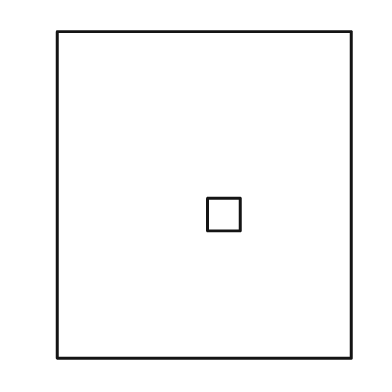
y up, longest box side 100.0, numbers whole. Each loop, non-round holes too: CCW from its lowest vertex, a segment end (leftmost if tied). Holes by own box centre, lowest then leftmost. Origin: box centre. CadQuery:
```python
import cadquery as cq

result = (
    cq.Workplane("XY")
    .moveTo(-45.0, -50.0)
    .lineTo(45.0, -50.0)
    .lineTo(45.0, 50.0)
    .lineTo(-45.0, 50.0)
    .close()
    .moveTo(1.0, -11.0)
    .lineTo(11.0, -11.0)
    .lineTo(11.0, -1.0)
    .lineTo(1.0, -1.0)
    .close()
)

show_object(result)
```